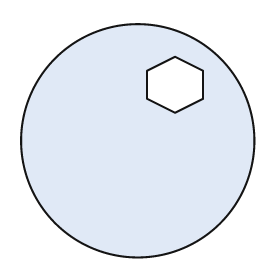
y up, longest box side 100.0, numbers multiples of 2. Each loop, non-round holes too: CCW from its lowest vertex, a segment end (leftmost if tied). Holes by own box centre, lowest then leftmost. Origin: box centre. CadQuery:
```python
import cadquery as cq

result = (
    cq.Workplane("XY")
    .moveTo(0.0, 0.0)
    .circle(50.0)
    .moveTo(16.0, 12.0)
    .lineTo(28.0, 18.0)
    .lineTo(28.0, 30.0)
    .lineTo(16.0, 36.0)
    .lineTo(4.0, 30.0)
    .lineTo(4.0, 18.0)
    .close()
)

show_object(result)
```